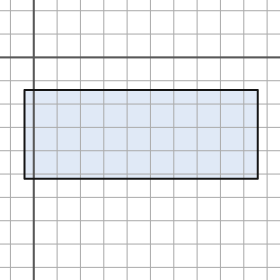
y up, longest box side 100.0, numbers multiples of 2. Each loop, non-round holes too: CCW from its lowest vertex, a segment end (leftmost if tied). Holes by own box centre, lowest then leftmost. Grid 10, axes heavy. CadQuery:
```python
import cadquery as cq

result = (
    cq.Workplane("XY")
    .moveTo(-4.0, -52.0)
    .lineTo(96.0, -52.0)
    .lineTo(96.0, -14.0)
    .lineTo(-4.0, -14.0)
    .close()
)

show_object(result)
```